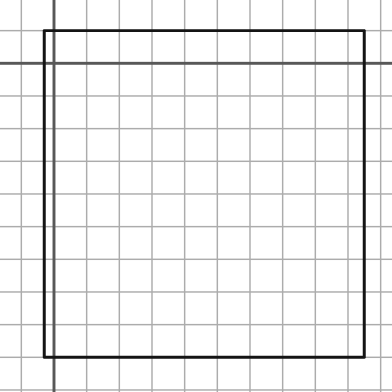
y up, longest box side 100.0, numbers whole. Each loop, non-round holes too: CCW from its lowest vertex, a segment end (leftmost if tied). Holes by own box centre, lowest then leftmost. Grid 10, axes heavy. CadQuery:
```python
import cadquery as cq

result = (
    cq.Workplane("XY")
    .moveTo(-3.0, -90.0)
    .lineTo(95.0, -90.0)
    .lineTo(95.0, 10.0)
    .lineTo(-3.0, 10.0)
    .close()
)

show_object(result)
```